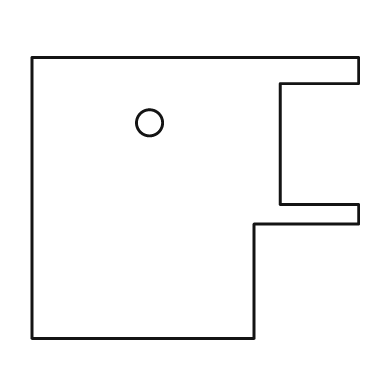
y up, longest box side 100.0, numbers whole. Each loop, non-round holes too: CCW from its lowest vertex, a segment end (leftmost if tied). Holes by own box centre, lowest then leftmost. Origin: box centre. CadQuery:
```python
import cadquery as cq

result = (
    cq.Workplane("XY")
    .moveTo(-50.0, -43.0)
    .lineTo(18.0, -43.0)
    .lineTo(18.0, -8.0)
    .lineTo(50.0, -8.0)
    .lineTo(50.0, -2.0)
    .lineTo(26.0, -2.0)
    .lineTo(26.0, 35.0)
    .lineTo(50.0, 35.0)
    .lineTo(50.0, 43.0)
    .lineTo(-50.0, 43.0)
    .close()
    .moveTo(-14.0, 23.0)
    .circle(4.0)
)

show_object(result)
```